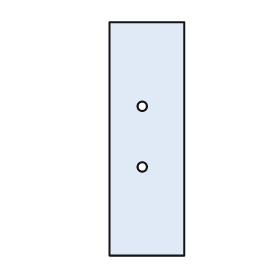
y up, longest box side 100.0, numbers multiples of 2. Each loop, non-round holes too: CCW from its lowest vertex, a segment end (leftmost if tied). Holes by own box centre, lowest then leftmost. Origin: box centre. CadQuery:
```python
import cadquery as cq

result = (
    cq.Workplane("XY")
    .moveTo(-16.0, -50.0)
    .lineTo(16.0, -50.0)
    .lineTo(16.0, 50.0)
    .lineTo(-16.0, 50.0)
    .close()
    .moveTo(-2.0, -12.0)
    .circle(2.0)
    .moveTo(-2.0, 14.0)
    .circle(2.0)
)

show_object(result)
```